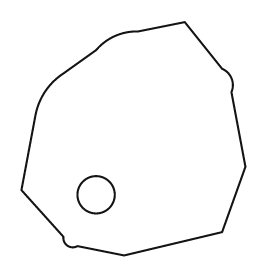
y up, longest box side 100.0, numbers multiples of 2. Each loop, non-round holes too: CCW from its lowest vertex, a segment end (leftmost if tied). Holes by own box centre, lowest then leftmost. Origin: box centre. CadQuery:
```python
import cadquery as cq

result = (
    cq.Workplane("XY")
    .moveTo(-4.0, -50.0)
    .lineTo(38.0, -40.0)
    .lineTo(48.0, -12.0)
    .lineTo(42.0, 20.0)
    .threePointArc((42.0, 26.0), (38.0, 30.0))
    .lineTo(22.0, 50.0)
    .lineTo(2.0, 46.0)
    .threePointArc((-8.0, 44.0), (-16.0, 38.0))
    .lineTo(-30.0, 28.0)
    .threePointArc((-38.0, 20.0), (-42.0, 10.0))
    .lineTo(-48.0, -22.0)
    .lineTo(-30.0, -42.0)
    .threePointArc((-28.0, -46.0), (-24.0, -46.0))
    .close()
    .moveTo(-16.0, -24.0)
    .circle(8.0)
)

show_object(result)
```